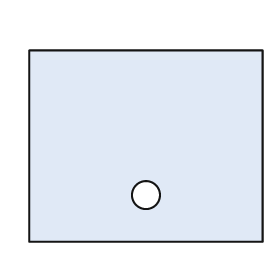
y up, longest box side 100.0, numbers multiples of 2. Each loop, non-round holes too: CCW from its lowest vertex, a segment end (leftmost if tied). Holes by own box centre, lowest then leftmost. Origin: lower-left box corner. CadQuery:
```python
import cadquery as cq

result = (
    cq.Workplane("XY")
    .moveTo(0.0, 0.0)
    .lineTo(100.0, 0.0)
    .lineTo(100.0, 82.0)
    .lineTo(0.0, 82.0)
    .close()
    .moveTo(50.0, 20.0)
    .circle(6.0)
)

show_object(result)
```